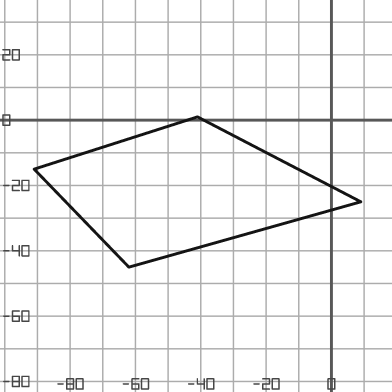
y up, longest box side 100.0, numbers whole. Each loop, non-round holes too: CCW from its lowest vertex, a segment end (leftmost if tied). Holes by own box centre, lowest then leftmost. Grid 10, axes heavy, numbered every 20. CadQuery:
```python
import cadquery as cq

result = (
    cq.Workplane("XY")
    .moveTo(-62.0, -45.0)
    .lineTo(9.0, -25.0)
    .lineTo(-41.0, 1.0)
    .lineTo(-91.0, -15.0)
    .close()
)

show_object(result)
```